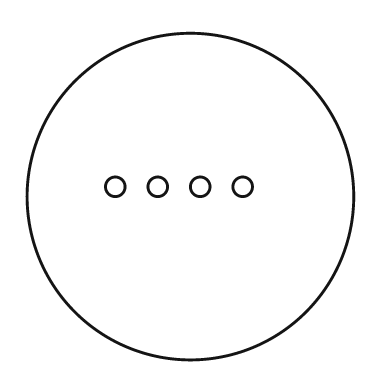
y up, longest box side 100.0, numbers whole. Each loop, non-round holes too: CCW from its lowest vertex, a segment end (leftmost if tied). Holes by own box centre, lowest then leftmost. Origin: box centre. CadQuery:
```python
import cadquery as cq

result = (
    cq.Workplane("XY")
    .moveTo(0.0, 0.0)
    .circle(50.0)
    .moveTo(-23.0, 3.0)
    .circle(3.0)
    .moveTo(-10.0, 3.0)
    .circle(3.0)
    .moveTo(3.0, 3.0)
    .circle(3.0)
    .moveTo(16.0, 3.0)
    .circle(3.0)
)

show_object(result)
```